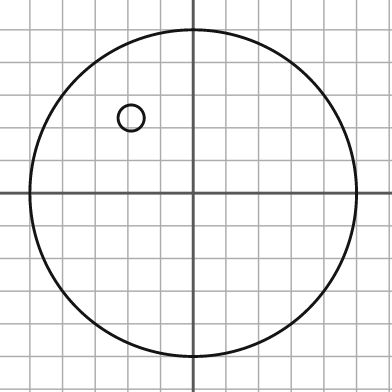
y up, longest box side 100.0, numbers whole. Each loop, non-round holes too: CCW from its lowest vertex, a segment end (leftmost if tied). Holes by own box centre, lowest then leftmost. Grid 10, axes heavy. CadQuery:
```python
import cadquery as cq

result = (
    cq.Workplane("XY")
    .moveTo(0.0, 0.0)
    .circle(50.0)
    .moveTo(-19.0, 23.0)
    .circle(4.0)
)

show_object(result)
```